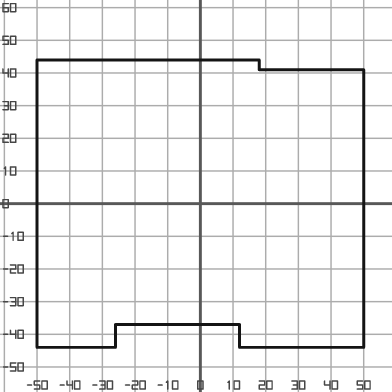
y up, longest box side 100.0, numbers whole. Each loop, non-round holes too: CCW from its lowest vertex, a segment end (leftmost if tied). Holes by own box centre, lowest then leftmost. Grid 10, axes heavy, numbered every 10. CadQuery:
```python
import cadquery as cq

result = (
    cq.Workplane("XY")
    .moveTo(-50.0, -44.0)
    .lineTo(-26.0, -44.0)
    .lineTo(-26.0, -37.0)
    .lineTo(12.0, -37.0)
    .lineTo(12.0, -44.0)
    .lineTo(50.0, -44.0)
    .lineTo(50.0, 41.0)
    .lineTo(18.0, 41.0)
    .lineTo(18.0, 44.0)
    .lineTo(-50.0, 44.0)
    .close()
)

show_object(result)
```